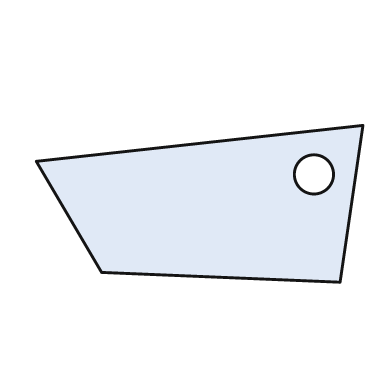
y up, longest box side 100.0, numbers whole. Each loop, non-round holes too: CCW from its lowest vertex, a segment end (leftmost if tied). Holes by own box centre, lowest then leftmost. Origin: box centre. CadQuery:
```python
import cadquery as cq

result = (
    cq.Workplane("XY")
    .moveTo(43.0, -24.0)
    .lineTo(50.0, 24.0)
    .lineTo(-50.0, 13.0)
    .lineTo(-30.0, -21.0)
    .close()
    .moveTo(35.0, 9.0)
    .circle(6.0)
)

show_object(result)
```